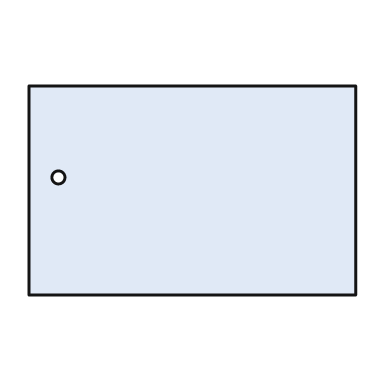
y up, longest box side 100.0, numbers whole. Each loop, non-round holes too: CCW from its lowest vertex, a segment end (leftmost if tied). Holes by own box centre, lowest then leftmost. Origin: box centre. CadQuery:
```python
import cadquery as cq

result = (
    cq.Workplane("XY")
    .moveTo(-50.0, -32.0)
    .lineTo(50.0, -32.0)
    .lineTo(50.0, 32.0)
    .lineTo(-50.0, 32.0)
    .close()
    .moveTo(-41.0, 4.0)
    .circle(2.0)
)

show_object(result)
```